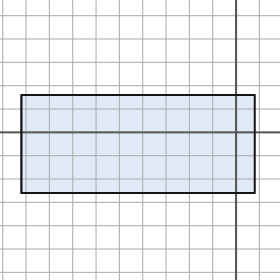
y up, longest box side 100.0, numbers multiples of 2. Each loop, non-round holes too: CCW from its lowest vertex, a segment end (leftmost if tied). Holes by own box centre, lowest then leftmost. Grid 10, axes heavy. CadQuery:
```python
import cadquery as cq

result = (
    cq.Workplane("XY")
    .moveTo(-92.0, -26.0)
    .lineTo(8.0, -26.0)
    .lineTo(8.0, 16.0)
    .lineTo(-92.0, 16.0)
    .close()
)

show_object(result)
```